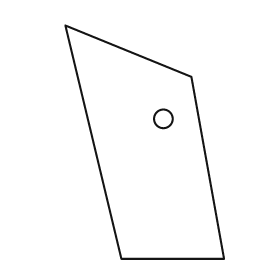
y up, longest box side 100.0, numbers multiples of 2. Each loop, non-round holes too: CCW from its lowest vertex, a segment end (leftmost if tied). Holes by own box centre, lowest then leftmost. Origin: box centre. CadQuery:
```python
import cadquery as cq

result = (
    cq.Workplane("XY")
    .moveTo(-10.0, -50.0)
    .lineTo(34.0, -50.0)
    .lineTo(20.0, 28.0)
    .lineTo(-34.0, 50.0)
    .close()
    .moveTo(8.0, 10.0)
    .circle(4.0)
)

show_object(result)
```